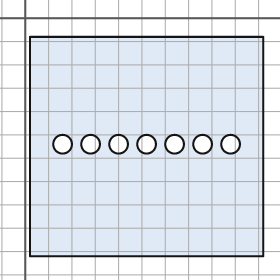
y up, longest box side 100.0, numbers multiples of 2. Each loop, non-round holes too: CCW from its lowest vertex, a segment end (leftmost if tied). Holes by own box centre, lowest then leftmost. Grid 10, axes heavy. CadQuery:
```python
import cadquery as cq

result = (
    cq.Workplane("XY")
    .moveTo(2.0, -102.0)
    .lineTo(102.0, -102.0)
    .lineTo(102.0, -8.0)
    .lineTo(2.0, -8.0)
    .close()
    .moveTo(16.0, -54.0)
    .circle(4.0)
    .moveTo(28.0, -54.0)
    .circle(4.0)
    .moveTo(40.0, -54.0)
    .circle(4.0)
    .moveTo(52.0, -54.0)
    .circle(4.0)
    .moveTo(64.0, -54.0)
    .circle(4.0)
    .moveTo(76.0, -54.0)
    .circle(4.0)
    .moveTo(88.0, -54.0)
    .circle(4.0)
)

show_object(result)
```